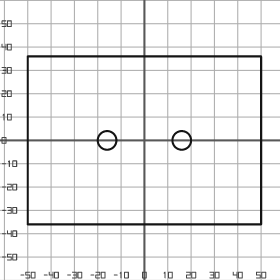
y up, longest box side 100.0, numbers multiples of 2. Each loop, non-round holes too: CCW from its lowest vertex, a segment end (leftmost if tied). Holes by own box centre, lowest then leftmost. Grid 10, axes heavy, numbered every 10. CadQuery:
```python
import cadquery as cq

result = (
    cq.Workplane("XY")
    .moveTo(-50.0, -36.0)
    .lineTo(50.0, -36.0)
    .lineTo(50.0, 36.0)
    .lineTo(-50.0, 36.0)
    .close()
    .moveTo(-16.0, 0.0)
    .circle(4.0)
    .moveTo(16.0, 0.0)
    .circle(4.0)
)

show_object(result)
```